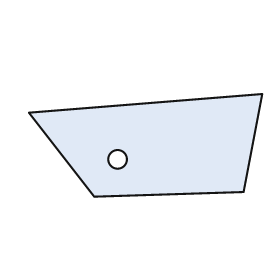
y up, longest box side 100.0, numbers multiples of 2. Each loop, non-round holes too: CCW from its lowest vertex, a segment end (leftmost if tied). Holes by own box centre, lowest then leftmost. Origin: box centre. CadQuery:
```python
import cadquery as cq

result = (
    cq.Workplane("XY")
    .moveTo(-22.0, -22.0)
    .lineTo(42.0, -20.0)
    .lineTo(50.0, 22.0)
    .lineTo(-50.0, 14.0)
    .close()
    .moveTo(-12.0, -6.0)
    .circle(4.0)
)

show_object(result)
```